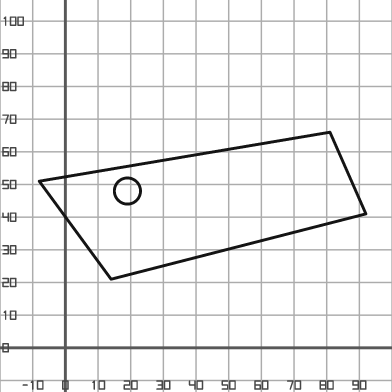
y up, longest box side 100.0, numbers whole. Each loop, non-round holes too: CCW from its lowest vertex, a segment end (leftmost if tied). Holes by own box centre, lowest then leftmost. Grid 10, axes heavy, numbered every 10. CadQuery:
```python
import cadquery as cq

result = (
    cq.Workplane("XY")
    .moveTo(14.0, 21.0)
    .lineTo(92.0, 41.0)
    .lineTo(81.0, 66.0)
    .lineTo(-8.0, 51.0)
    .close()
    .moveTo(19.0, 48.0)
    .circle(4.0)
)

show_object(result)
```